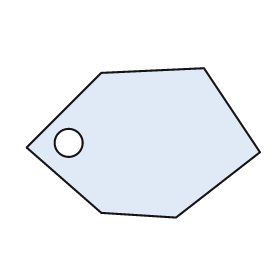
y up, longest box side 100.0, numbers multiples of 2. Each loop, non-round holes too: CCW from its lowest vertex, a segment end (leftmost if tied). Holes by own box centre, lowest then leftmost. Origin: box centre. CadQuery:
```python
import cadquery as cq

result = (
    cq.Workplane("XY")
    .moveTo(14.0, -32.0)
    .lineTo(50.0, -4.0)
    .lineTo(26.0, 32.0)
    .lineTo(-18.0, 30.0)
    .lineTo(-50.0, -2.0)
    .lineTo(-18.0, -30.0)
    .close()
    .moveTo(-32.0, 0.0)
    .circle(6.0)
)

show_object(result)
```